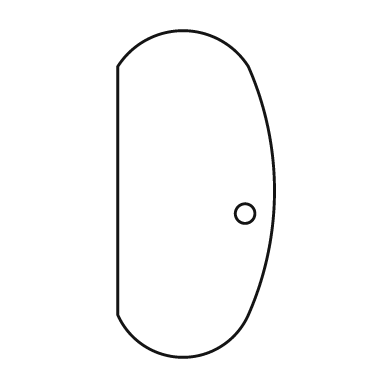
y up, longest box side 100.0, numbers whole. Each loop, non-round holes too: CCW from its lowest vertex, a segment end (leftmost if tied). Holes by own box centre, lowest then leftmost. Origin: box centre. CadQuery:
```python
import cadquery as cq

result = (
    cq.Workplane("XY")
    .moveTo(-24.0, -37.0)
    .threePointArc((-4.0, -50.0), (16.0, -37.0))
    .threePointArc((24.0, 1.0), (16.0, 39.0))
    .threePointArc((-4.0, 50.0), (-24.0, 39.0))
    .close()
    .moveTo(15.0, -6.0)
    .circle(3.0)
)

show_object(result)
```